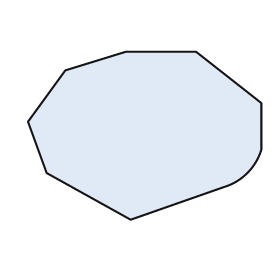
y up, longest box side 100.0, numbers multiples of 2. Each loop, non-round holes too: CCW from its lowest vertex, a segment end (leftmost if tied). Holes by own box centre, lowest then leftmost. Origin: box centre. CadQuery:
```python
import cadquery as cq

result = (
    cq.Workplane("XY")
    .moveTo(-6.0, -36.0)
    .lineTo(34.0, -22.0)
    .threePointArc((44.0, -16.0), (50.0, -6.0))
    .lineTo(50.0, 14.0)
    .lineTo(22.0, 36.0)
    .lineTo(-8.0, 36.0)
    .lineTo(-34.0, 28.0)
    .lineTo(-50.0, 6.0)
    .lineTo(-42.0, -16.0)
    .close()
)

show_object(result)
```